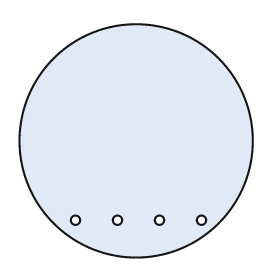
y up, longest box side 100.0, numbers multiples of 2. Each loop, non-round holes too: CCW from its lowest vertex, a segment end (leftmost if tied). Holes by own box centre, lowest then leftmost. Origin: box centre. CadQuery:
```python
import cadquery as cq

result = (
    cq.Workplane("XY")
    .moveTo(0.0, 0.0)
    .circle(50.0)
    .moveTo(-26.0, -34.0)
    .circle(2.0)
    .moveTo(-8.0, -34.0)
    .circle(2.0)
    .moveTo(10.0, -34.0)
    .circle(2.0)
    .moveTo(28.0, -34.0)
    .circle(2.0)
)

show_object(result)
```